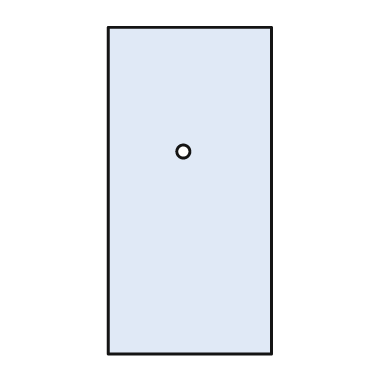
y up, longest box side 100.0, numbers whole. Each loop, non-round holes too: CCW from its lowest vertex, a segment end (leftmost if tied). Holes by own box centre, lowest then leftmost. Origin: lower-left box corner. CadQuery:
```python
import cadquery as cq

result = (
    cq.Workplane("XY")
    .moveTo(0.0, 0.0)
    .lineTo(50.0, 0.0)
    .lineTo(50.0, 100.0)
    .lineTo(0.0, 100.0)
    .close()
    .moveTo(23.0, 62.0)
    .circle(2.0)
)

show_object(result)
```